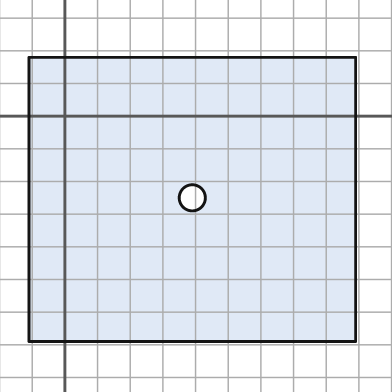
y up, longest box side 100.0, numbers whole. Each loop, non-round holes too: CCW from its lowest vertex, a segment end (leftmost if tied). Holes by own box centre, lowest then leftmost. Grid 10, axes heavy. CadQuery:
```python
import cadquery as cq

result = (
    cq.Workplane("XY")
    .moveTo(-11.0, -69.0)
    .lineTo(89.0, -69.0)
    .lineTo(89.0, 18.0)
    .lineTo(-11.0, 18.0)
    .close()
    .moveTo(39.0, -25.0)
    .circle(4.0)
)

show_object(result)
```